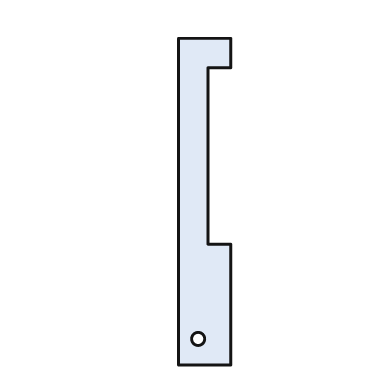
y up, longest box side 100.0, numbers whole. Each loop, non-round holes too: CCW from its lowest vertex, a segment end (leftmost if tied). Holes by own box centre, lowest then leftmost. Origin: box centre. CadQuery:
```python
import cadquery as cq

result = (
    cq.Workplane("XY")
    .moveTo(-8.0, -50.0)
    .lineTo(8.0, -50.0)
    .lineTo(8.0, -13.0)
    .lineTo(1.0, -13.0)
    .lineTo(1.0, 41.0)
    .lineTo(8.0, 41.0)
    .lineTo(8.0, 50.0)
    .lineTo(-8.0, 50.0)
    .close()
    .moveTo(-2.0, -42.0)
    .circle(2.0)
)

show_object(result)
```